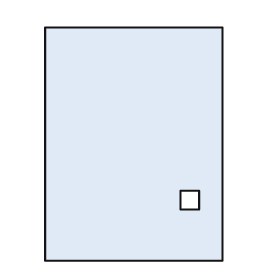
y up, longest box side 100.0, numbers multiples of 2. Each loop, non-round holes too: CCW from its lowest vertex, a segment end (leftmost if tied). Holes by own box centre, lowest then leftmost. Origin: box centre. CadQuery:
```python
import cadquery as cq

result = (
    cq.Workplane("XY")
    .moveTo(-38.0, -50.0)
    .lineTo(38.0, -50.0)
    .lineTo(38.0, 50.0)
    .lineTo(-38.0, 50.0)
    .close()
    .moveTo(20.0, -28.0)
    .lineTo(28.0, -28.0)
    .lineTo(28.0, -20.0)
    .lineTo(20.0, -20.0)
    .close()
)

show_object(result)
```